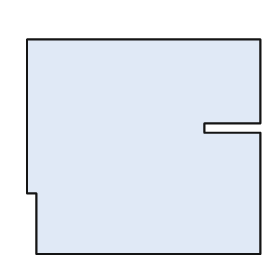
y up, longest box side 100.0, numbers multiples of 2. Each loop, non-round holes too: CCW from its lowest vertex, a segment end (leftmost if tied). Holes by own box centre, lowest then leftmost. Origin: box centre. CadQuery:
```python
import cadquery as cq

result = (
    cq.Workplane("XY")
    .moveTo(-46.0, -46.0)
    .lineTo(50.0, -46.0)
    .lineTo(50.0, 6.0)
    .lineTo(26.0, 6.0)
    .lineTo(26.0, 10.0)
    .lineTo(50.0, 10.0)
    .lineTo(50.0, 46.0)
    .lineTo(-50.0, 46.0)
    .lineTo(-50.0, -20.0)
    .lineTo(-46.0, -20.0)
    .close()
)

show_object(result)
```